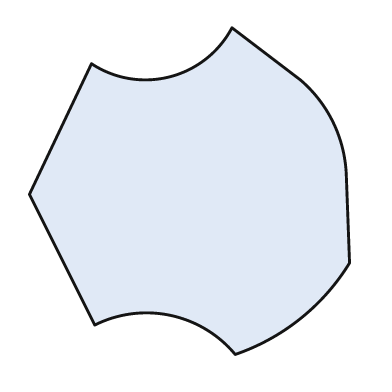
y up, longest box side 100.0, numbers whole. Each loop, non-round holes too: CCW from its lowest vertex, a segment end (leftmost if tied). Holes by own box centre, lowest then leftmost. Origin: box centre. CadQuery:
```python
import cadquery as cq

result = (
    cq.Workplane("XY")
    .moveTo(14.0, -50.0)
    .threePointArc((34.0, -39.0), (49.0, -22.0))
    .lineTo(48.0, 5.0)
    .threePointArc((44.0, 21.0), (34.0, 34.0))
    .lineTo(13.0, 50.0)
    .threePointArc((-6.0, 35.0), (-30.0, 39.0))
    .lineTo(-49.0, -1.0)
    .lineTo(-29.0, -41.0)
    .threePointArc((-6.0, -38.0), (14.0, -50.0))
    .close()
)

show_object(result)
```